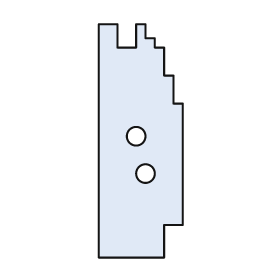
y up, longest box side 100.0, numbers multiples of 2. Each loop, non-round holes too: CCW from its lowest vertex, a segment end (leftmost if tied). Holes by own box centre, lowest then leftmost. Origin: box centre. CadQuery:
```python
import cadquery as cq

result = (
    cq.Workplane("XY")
    .moveTo(-18.0, -50.0)
    .lineTo(10.0, -50.0)
    .lineTo(10.0, -36.0)
    .lineTo(18.0, -36.0)
    .lineTo(18.0, 16.0)
    .lineTo(14.0, 16.0)
    .lineTo(14.0, 28.0)
    .lineTo(10.0, 28.0)
    .lineTo(10.0, 40.0)
    .lineTo(6.0, 40.0)
    .lineTo(6.0, 44.0)
    .lineTo(2.0, 44.0)
    .lineTo(2.0, 50.0)
    .lineTo(-2.0, 50.0)
    .lineTo(-2.0, 40.0)
    .lineTo(-10.0, 40.0)
    .lineTo(-10.0, 50.0)
    .lineTo(-18.0, 50.0)
    .close()
    .moveTo(2.0, -14.0)
    .circle(4.0)
    .moveTo(-2.0, 2.0)
    .circle(4.0)
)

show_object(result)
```